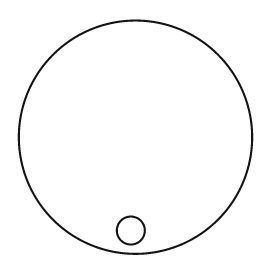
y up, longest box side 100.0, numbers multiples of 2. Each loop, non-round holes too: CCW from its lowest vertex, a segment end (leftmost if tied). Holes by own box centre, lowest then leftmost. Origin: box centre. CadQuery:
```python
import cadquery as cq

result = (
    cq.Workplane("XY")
    .moveTo(0.0, 0.0)
    .circle(50.0)
    .moveTo(-2.0, -40.0)
    .circle(6.0)
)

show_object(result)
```